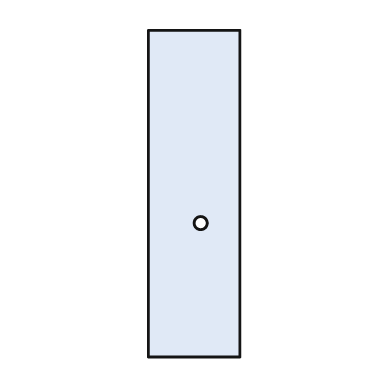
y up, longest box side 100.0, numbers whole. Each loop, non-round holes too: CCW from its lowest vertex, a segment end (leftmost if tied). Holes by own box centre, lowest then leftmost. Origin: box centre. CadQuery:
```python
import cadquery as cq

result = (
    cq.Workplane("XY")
    .moveTo(-14.0, -50.0)
    .lineTo(14.0, -50.0)
    .lineTo(14.0, 50.0)
    .lineTo(-14.0, 50.0)
    .close()
    .moveTo(2.0, -9.0)
    .circle(2.0)
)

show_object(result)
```